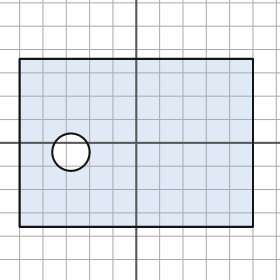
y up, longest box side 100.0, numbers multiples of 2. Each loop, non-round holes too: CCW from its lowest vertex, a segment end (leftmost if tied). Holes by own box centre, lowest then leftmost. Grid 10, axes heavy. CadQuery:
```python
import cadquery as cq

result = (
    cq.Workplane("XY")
    .moveTo(-50.0, -36.0)
    .lineTo(50.0, -36.0)
    .lineTo(50.0, 36.0)
    .lineTo(-50.0, 36.0)
    .close()
    .moveTo(-28.0, -4.0)
    .circle(8.0)
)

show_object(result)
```